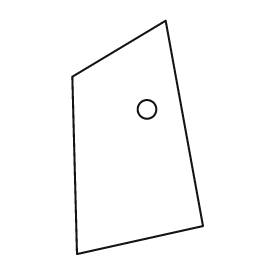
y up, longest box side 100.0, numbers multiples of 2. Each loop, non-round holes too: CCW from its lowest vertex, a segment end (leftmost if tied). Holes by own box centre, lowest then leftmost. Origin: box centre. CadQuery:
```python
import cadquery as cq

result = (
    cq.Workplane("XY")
    .moveTo(-26.0, -50.0)
    .lineTo(28.0, -38.0)
    .lineTo(12.0, 50.0)
    .lineTo(-28.0, 26.0)
    .close()
    .moveTo(4.0, 12.0)
    .circle(4.0)
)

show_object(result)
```